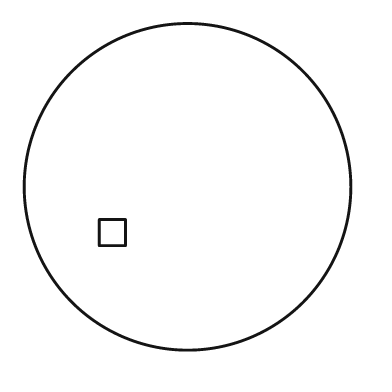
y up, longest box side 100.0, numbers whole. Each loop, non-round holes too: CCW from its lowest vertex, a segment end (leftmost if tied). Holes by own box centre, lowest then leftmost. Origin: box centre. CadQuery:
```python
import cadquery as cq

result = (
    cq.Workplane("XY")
    .moveTo(0.0, 0.0)
    .circle(50.0)
    .moveTo(-27.0, -18.0)
    .lineTo(-19.0, -18.0)
    .lineTo(-19.0, -10.0)
    .lineTo(-27.0, -10.0)
    .close()
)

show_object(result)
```